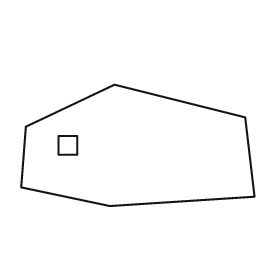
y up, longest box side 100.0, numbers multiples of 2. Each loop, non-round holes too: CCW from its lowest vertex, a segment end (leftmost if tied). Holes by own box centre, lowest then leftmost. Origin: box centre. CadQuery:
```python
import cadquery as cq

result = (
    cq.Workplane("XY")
    .moveTo(-12.0, -26.0)
    .lineTo(50.0, -22.0)
    .lineTo(46.0, 12.0)
    .lineTo(-10.0, 26.0)
    .lineTo(-48.0, 8.0)
    .lineTo(-50.0, -18.0)
    .close()
    .moveTo(-34.0, -4.0)
    .lineTo(-26.0, -4.0)
    .lineTo(-26.0, 4.0)
    .lineTo(-34.0, 4.0)
    .close()
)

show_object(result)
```